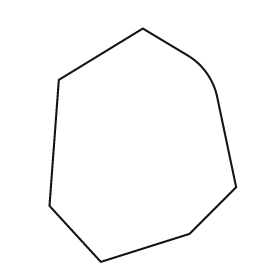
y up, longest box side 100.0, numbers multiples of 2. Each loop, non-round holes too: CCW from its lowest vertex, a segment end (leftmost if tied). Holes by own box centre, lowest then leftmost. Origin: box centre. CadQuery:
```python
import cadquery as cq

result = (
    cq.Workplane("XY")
    .moveTo(-18.0, -50.0)
    .lineTo(20.0, -38.0)
    .lineTo(40.0, -18.0)
    .lineTo(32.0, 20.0)
    .threePointArc((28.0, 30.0), (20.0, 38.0))
    .lineTo(0.0, 50.0)
    .lineTo(-36.0, 28.0)
    .lineTo(-40.0, -26.0)
    .close()
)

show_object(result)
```